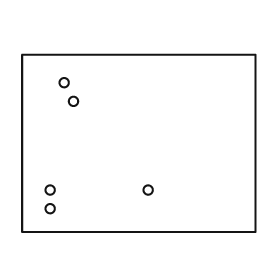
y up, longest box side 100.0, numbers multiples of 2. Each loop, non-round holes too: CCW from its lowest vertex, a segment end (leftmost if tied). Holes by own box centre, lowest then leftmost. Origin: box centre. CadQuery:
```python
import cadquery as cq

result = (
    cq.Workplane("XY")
    .moveTo(-50.0, -38.0)
    .lineTo(50.0, -38.0)
    .lineTo(50.0, 38.0)
    .lineTo(-50.0, 38.0)
    .close()
    .moveTo(-38.0, -28.0)
    .circle(2.0)
    .moveTo(-38.0, -20.0)
    .circle(2.0)
    .moveTo(4.0, -20.0)
    .circle(2.0)
    .moveTo(-28.0, 18.0)
    .circle(2.0)
    .moveTo(-32.0, 26.0)
    .circle(2.0)
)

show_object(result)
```